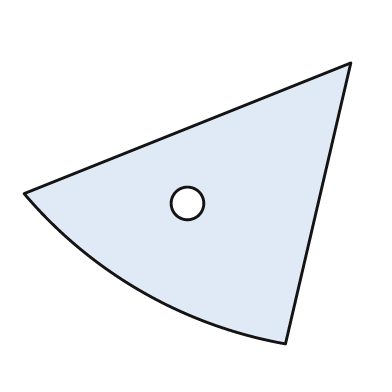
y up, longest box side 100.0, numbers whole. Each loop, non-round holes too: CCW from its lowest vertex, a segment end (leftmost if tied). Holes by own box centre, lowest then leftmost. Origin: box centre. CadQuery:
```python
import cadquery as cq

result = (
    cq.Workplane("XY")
    .moveTo(30.0, -43.0)
    .lineTo(50.0, 43.0)
    .lineTo(-50.0, 3.0)
    .threePointArc((-14.0, -27.0), (30.0, -43.0))
    .close()
    .moveTo(0.0, 0.0)
    .circle(5.0)
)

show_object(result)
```